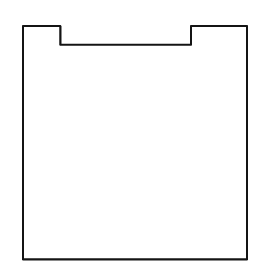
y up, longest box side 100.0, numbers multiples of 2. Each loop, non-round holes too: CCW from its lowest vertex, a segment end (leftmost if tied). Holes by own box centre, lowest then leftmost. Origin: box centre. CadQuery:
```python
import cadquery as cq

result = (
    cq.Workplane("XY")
    .moveTo(-48.0, -50.0)
    .lineTo(48.0, -50.0)
    .lineTo(48.0, 50.0)
    .lineTo(24.0, 50.0)
    .lineTo(24.0, 42.0)
    .lineTo(-32.0, 42.0)
    .lineTo(-32.0, 50.0)
    .lineTo(-48.0, 50.0)
    .close()
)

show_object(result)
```